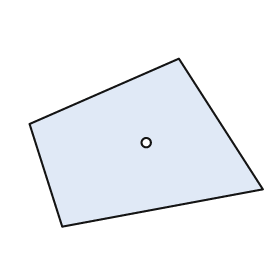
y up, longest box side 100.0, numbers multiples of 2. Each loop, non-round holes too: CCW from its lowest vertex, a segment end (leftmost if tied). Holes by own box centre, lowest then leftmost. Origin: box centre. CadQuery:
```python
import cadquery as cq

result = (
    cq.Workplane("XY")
    .moveTo(-36.0, -36.0)
    .lineTo(50.0, -20.0)
    .lineTo(14.0, 36.0)
    .lineTo(-50.0, 8.0)
    .close()
    .moveTo(0.0, 0.0)
    .circle(2.0)
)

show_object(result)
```